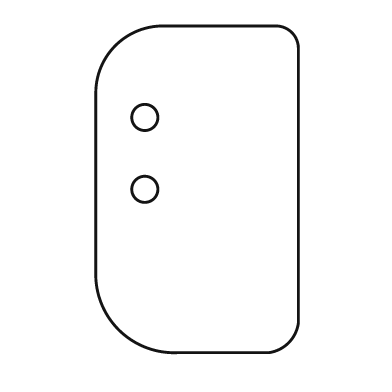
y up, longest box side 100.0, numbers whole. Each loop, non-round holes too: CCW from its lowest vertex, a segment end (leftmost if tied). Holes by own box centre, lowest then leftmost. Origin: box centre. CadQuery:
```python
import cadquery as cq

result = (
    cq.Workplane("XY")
    .moveTo(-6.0, -50.0)
    .lineTo(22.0, -50.0)
    .threePointArc((28.0, -47.0), (31.0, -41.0))
    .lineTo(31.0, 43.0)
    .threePointArc((29.0, 48.0), (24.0, 50.0))
    .lineTo(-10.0, 50.0)
    .threePointArc((-25.0, 44.0), (-31.0, 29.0))
    .lineTo(-31.0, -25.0)
    .threePointArc((-24.0, -43.0), (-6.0, -50.0))
    .close()
    .moveTo(-16.0, 0.0)
    .circle(4.0)
    .moveTo(-16.0, 22.0)
    .circle(4.0)
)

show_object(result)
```